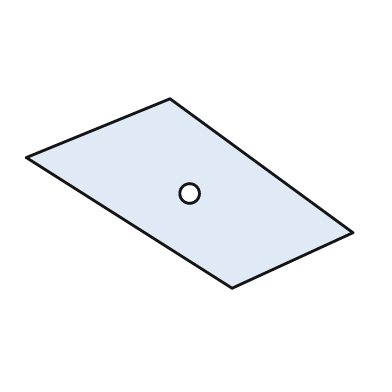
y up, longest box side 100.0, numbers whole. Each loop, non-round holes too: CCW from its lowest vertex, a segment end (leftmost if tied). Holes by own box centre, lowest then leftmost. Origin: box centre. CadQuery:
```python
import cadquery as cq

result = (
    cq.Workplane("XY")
    .moveTo(13.0, -29.0)
    .lineTo(50.0, -12.0)
    .lineTo(-6.0, 29.0)
    .lineTo(-50.0, 11.0)
    .close()
    .moveTo(0.0, 0.0)
    .circle(3.0)
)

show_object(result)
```